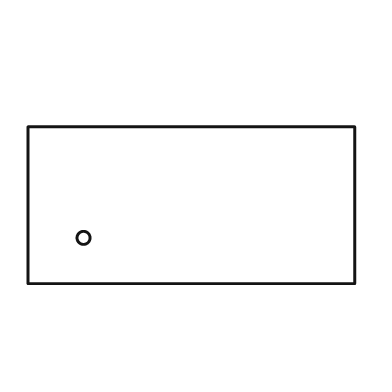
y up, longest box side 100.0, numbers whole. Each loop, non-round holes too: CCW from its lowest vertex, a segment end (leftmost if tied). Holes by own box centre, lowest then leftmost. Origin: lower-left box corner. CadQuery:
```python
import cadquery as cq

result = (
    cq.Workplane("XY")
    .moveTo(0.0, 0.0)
    .lineTo(100.0, 0.0)
    .lineTo(100.0, 48.0)
    .lineTo(0.0, 48.0)
    .close()
    .moveTo(17.0, 14.0)
    .circle(2.0)
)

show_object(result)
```